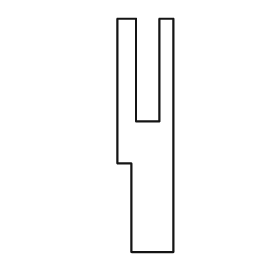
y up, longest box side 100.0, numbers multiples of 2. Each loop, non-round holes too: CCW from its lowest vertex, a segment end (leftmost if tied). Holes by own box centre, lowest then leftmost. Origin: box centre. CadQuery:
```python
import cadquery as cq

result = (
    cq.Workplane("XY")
    .moveTo(-6.0, -50.0)
    .lineTo(12.0, -50.0)
    .lineTo(12.0, 50.0)
    .lineTo(6.0, 50.0)
    .lineTo(6.0, 6.0)
    .lineTo(-4.0, 6.0)
    .lineTo(-4.0, 50.0)
    .lineTo(-12.0, 50.0)
    .lineTo(-12.0, -12.0)
    .lineTo(-6.0, -12.0)
    .close()
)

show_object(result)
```